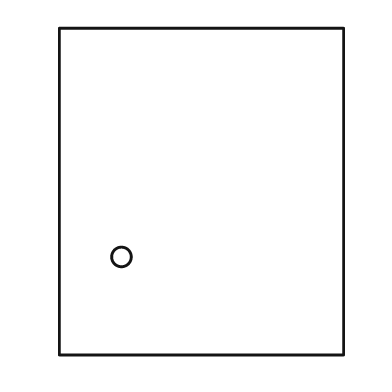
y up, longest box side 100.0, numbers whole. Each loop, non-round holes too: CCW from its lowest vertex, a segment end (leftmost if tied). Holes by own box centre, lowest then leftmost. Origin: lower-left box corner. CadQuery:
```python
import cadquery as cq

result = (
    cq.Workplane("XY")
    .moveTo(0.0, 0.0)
    .lineTo(87.0, 0.0)
    .lineTo(87.0, 100.0)
    .lineTo(0.0, 100.0)
    .close()
    .moveTo(19.0, 30.0)
    .circle(3.0)
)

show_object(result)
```